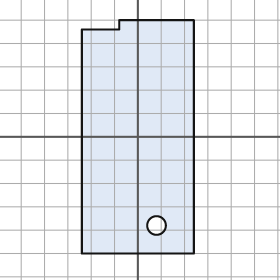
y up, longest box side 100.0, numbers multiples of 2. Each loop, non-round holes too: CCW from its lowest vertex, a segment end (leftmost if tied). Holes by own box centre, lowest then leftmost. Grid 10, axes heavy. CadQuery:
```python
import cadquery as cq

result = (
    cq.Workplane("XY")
    .moveTo(-24.0, -50.0)
    .lineTo(24.0, -50.0)
    .lineTo(24.0, 50.0)
    .lineTo(-8.0, 50.0)
    .lineTo(-8.0, 46.0)
    .lineTo(-24.0, 46.0)
    .close()
    .moveTo(8.0, -38.0)
    .circle(4.0)
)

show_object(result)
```